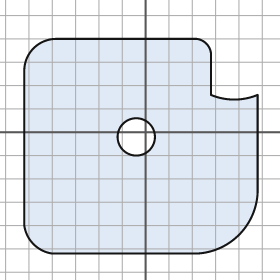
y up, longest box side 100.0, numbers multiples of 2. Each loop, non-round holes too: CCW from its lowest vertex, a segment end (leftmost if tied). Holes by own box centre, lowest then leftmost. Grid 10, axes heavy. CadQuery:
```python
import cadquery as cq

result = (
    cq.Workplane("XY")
    .moveTo(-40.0, -52.0)
    .lineTo(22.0, -52.0)
    .threePointArc((40.0, -44.0), (48.0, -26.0))
    .lineTo(48.0, 16.0)
    .threePointArc((38.0, 14.0), (28.0, 16.0))
    .lineTo(28.0, 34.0)
    .threePointArc((26.0, 38.0), (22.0, 40.0))
    .lineTo(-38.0, 40.0)
    .threePointArc((-48.0, 36.0), (-52.0, 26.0))
    .lineTo(-52.0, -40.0)
    .threePointArc((-48.0, -48.0), (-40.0, -52.0))
    .close()
    .moveTo(-4.0, -2.0)
    .circle(8.0)
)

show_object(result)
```